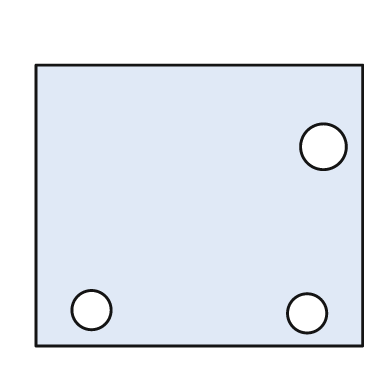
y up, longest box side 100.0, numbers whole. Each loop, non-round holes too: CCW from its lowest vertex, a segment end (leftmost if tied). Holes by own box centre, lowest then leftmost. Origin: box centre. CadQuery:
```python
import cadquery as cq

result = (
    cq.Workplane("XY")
    .moveTo(-50.0, -43.0)
    .lineTo(50.0, -43.0)
    .lineTo(50.0, 43.0)
    .lineTo(-50.0, 43.0)
    .close()
    .moveTo(33.0, -33.0)
    .circle(6.0)
    .moveTo(-33.0, -32.0)
    .circle(6.0)
    .moveTo(38.0, 18.0)
    .circle(7.0)
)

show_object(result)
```